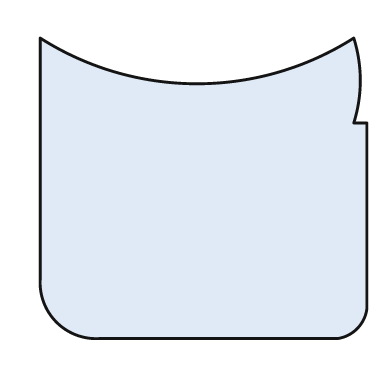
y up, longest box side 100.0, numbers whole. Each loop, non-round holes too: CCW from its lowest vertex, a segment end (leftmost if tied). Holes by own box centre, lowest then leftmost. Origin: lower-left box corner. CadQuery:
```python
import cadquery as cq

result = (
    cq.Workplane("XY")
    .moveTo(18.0, 0.0)
    .lineTo(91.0, 0.0)
    .threePointArc((97.0, 3.0), (100.0, 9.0))
    .lineTo(100.0, 66.0)
    .lineTo(96.0, 66.0)
    .threePointArc((98.0, 79.0), (96.0, 92.0))
    .threePointArc((48.0, 78.0), (0.0, 92.0))
    .lineTo(0.0, 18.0)
    .threePointArc((5.0, 5.0), (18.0, 0.0))
    .close()
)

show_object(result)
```